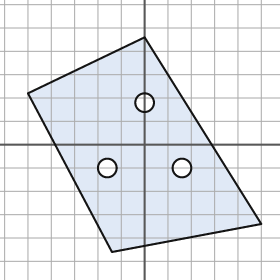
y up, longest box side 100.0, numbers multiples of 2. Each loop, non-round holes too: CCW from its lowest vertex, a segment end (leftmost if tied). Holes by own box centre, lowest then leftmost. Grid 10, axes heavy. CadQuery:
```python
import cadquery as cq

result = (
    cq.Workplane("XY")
    .moveTo(-14.0, -46.0)
    .lineTo(50.0, -34.0)
    .lineTo(0.0, 46.0)
    .lineTo(-50.0, 22.0)
    .close()
    .moveTo(-16.0, -10.0)
    .circle(4.0)
    .moveTo(16.0, -10.0)
    .circle(4.0)
    .moveTo(0.0, 18.0)
    .circle(4.0)
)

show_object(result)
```